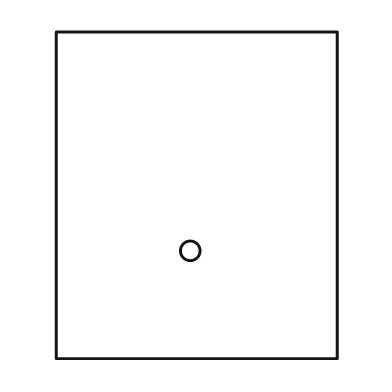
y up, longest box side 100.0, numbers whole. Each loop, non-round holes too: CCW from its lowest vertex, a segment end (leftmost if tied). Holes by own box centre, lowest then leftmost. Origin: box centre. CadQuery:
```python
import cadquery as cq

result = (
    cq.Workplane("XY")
    .moveTo(-43.0, -50.0)
    .lineTo(43.0, -50.0)
    .lineTo(43.0, 50.0)
    .lineTo(-43.0, 50.0)
    .close()
    .moveTo(-2.0, -17.0)
    .circle(3.0)
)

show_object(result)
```